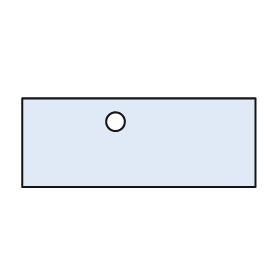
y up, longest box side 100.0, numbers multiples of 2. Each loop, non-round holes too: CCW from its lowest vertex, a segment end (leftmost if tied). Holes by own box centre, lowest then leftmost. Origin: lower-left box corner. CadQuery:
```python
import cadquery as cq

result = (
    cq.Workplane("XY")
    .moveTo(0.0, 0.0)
    .lineTo(100.0, 0.0)
    .lineTo(100.0, 38.0)
    .lineTo(0.0, 38.0)
    .close()
    .moveTo(40.0, 28.0)
    .circle(4.0)
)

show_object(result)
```